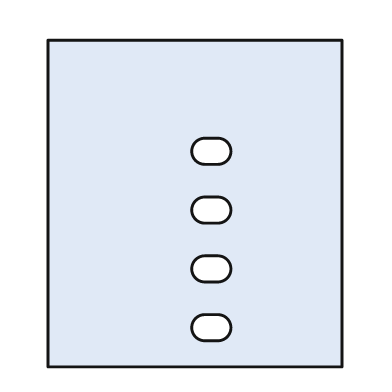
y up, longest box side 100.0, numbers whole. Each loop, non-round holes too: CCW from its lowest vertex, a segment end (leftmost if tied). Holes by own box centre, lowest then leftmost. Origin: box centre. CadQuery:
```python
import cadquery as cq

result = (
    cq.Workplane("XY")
    .moveTo(-45.0, -50.0)
    .lineTo(45.0, -50.0)
    .lineTo(45.0, 50.0)
    .lineTo(-45.0, 50.0)
    .close()
    .moveTo(3.0, -42.0)
    .lineTo(7.0, -42.0)
    .threePointArc((11.0, -38.0), (7.0, -34.0))
    .lineTo(3.0, -34.0)
    .threePointArc((-1.0, -38.0), (3.0, -42.0))
    .close()
    .moveTo(3.0, -24.0)
    .lineTo(7.0, -24.0)
    .threePointArc((11.0, -20.0), (7.0, -16.0))
    .lineTo(3.0, -16.0)
    .threePointArc((-1.0, -20.0), (3.0, -24.0))
    .close()
    .moveTo(3.0, -6.0)
    .lineTo(7.0, -6.0)
    .threePointArc((11.0, -2.0), (7.0, 2.0))
    .lineTo(3.0, 2.0)
    .threePointArc((-1.0, -2.0), (3.0, -6.0))
    .close()
    .moveTo(3.0, 12.0)
    .lineTo(7.0, 12.0)
    .threePointArc((11.0, 16.0), (7.0, 20.0))
    .lineTo(3.0, 20.0)
    .threePointArc((-1.0, 16.0), (3.0, 12.0))
    .close()
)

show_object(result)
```